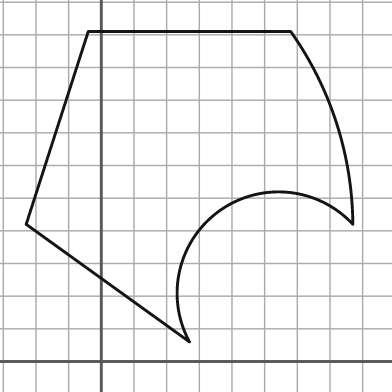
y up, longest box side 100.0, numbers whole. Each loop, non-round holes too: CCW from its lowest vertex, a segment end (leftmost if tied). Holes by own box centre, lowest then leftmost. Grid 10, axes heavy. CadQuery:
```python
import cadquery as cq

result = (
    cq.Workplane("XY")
    .moveTo(27.0, 6.0)
    .threePointArc((36.0, 46.0), (77.0, 42.0))
    .threePointArc((72.0, 73.0), (58.0, 101.0))
    .lineTo(-4.0, 101.0)
    .lineTo(-23.0, 42.0)
    .close()
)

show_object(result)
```